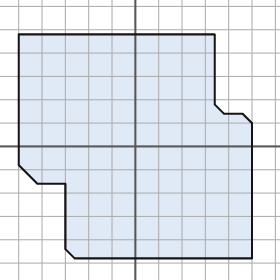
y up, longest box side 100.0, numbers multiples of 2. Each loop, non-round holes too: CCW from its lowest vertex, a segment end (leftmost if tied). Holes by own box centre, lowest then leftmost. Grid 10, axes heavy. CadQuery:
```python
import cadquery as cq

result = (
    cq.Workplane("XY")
    .moveTo(-26.0, -48.0)
    .lineTo(50.0, -48.0)
    .lineTo(50.0, 10.0)
    .lineTo(46.0, 14.0)
    .lineTo(38.0, 14.0)
    .lineTo(34.0, 18.0)
    .lineTo(34.0, 48.0)
    .lineTo(-50.0, 48.0)
    .lineTo(-50.0, -8.0)
    .lineTo(-42.0, -16.0)
    .lineTo(-30.0, -16.0)
    .lineTo(-30.0, -44.0)
    .close()
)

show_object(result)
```